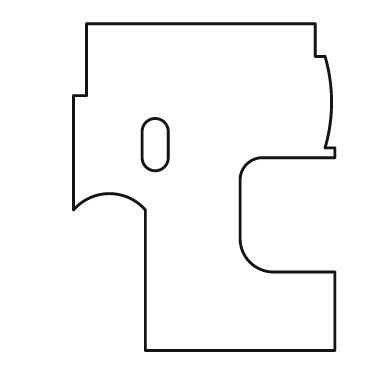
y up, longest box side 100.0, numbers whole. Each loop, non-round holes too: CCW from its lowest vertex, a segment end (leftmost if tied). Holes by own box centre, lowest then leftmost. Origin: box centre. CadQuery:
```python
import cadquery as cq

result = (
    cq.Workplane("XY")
    .moveTo(-18.0, -50.0)
    .lineTo(40.0, -50.0)
    .lineTo(40.0, -26.0)
    .lineTo(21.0, -26.0)
    .threePointArc((14.0, -23.0), (11.0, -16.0))
    .lineTo(11.0, 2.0)
    .threePointArc((13.0, 7.0), (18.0, 9.0))
    .lineTo(40.0, 9.0)
    .lineTo(40.0, 12.0)
    .lineTo(37.0, 12.0)
    .threePointArc((39.0, 26.0), (37.0, 40.0))
    .lineTo(34.0, 40.0)
    .lineTo(34.0, 50.0)
    .lineTo(-36.0, 50.0)
    .lineTo(-36.0, 28.0)
    .lineTo(-40.0, 28.0)
    .lineTo(-40.0, -7.0)
    .threePointArc((-29.0, -2.0), (-18.0, -7.0))
    .close()
    .moveTo(-19.0, 9.0)
    .threePointArc((-15.0, 5.0), (-11.0, 9.0))
    .lineTo(-11.0, 17.0)
    .threePointArc((-15.0, 21.0), (-19.0, 17.0))
    .close()
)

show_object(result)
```